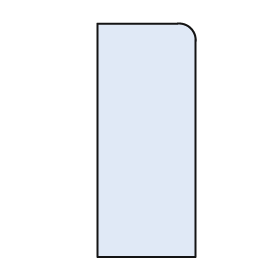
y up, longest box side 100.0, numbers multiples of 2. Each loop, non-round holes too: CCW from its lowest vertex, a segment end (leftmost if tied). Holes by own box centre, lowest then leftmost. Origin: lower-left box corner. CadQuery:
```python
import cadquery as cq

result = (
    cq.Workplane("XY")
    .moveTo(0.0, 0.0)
    .lineTo(42.0, 0.0)
    .lineTo(42.0, 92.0)
    .threePointArc((40.0, 98.0), (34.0, 100.0))
    .lineTo(0.0, 100.0)
    .close()
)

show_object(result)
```